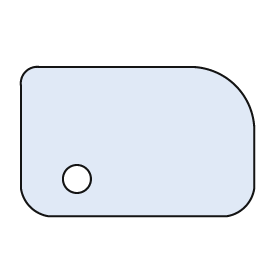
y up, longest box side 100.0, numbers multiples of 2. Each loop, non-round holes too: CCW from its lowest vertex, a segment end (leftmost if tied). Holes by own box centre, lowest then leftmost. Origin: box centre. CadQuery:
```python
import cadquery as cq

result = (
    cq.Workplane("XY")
    .moveTo(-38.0, -32.0)
    .lineTo(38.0, -32.0)
    .threePointArc((46.0, -28.0), (50.0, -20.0))
    .lineTo(50.0, 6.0)
    .threePointArc((42.0, 24.0), (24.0, 32.0))
    .lineTo(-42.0, 32.0)
    .threePointArc((-48.0, 30.0), (-50.0, 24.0))
    .lineTo(-50.0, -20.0)
    .threePointArc((-46.0, -28.0), (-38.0, -32.0))
    .close()
    .moveTo(-26.0, -16.0)
    .circle(6.0)
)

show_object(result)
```